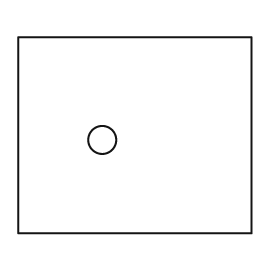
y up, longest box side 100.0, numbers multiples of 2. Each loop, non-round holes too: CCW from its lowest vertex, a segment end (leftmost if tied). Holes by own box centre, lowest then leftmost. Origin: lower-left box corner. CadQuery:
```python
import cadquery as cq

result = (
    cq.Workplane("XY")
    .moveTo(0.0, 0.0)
    .lineTo(100.0, 0.0)
    .lineTo(100.0, 84.0)
    .lineTo(0.0, 84.0)
    .close()
    .moveTo(36.0, 40.0)
    .circle(6.0)
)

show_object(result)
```